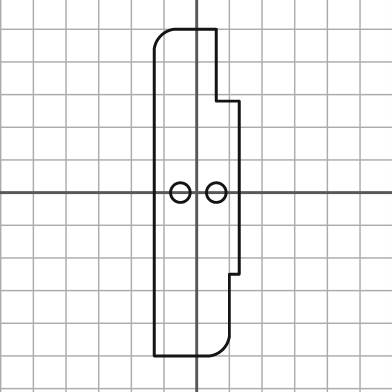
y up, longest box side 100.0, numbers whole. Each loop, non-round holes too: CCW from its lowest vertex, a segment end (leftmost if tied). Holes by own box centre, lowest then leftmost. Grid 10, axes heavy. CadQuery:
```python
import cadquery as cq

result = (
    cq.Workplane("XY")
    .moveTo(-13.0, -50.0)
    .lineTo(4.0, -50.0)
    .threePointArc((8.0, -48.0), (10.0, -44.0))
    .lineTo(10.0, -25.0)
    .lineTo(13.0, -25.0)
    .lineTo(13.0, 28.0)
    .lineTo(6.0, 28.0)
    .lineTo(6.0, 50.0)
    .lineTo(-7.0, 50.0)
    .threePointArc((-11.0, 48.0), (-13.0, 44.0))
    .close()
    .moveTo(-5.0, 0.0)
    .circle(3.0)
    .moveTo(6.0, 0.0)
    .circle(3.0)
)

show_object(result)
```